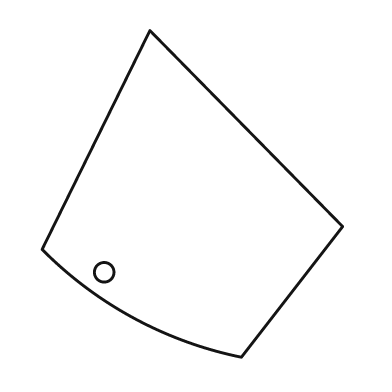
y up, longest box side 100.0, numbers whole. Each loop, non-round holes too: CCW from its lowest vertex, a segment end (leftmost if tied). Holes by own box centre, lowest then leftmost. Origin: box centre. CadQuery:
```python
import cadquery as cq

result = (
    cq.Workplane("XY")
    .moveTo(15.0, -50.0)
    .lineTo(46.0, -10.0)
    .lineTo(-13.0, 50.0)
    .lineTo(-46.0, -17.0)
    .threePointArc((-18.0, -38.0), (15.0, -50.0))
    .close()
    .moveTo(-27.0, -24.0)
    .circle(3.0)
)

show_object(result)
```